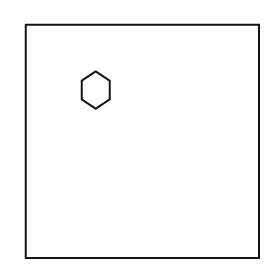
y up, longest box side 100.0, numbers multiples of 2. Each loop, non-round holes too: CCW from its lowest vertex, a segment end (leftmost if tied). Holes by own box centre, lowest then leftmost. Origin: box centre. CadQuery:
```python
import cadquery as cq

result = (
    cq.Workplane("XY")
    .moveTo(-50.0, -50.0)
    .lineTo(50.0, -50.0)
    .lineTo(50.0, 50.0)
    .lineTo(-50.0, 50.0)
    .close()
    .moveTo(-20.0, 14.0)
    .lineTo(-14.0, 18.0)
    .lineTo(-14.0, 26.0)
    .lineTo(-20.0, 30.0)
    .lineTo(-26.0, 26.0)
    .lineTo(-26.0, 18.0)
    .close()
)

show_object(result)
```